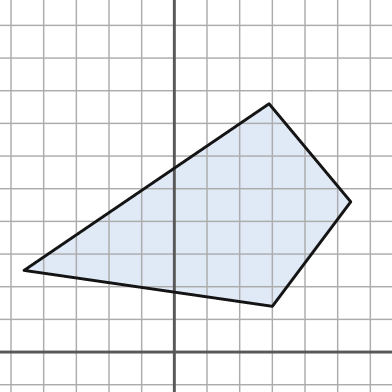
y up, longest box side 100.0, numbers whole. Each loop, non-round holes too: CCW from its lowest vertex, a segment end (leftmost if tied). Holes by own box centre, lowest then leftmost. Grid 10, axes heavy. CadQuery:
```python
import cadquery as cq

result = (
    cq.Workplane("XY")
    .moveTo(30.0, 14.0)
    .lineTo(54.0, 46.0)
    .lineTo(29.0, 76.0)
    .lineTo(-46.0, 25.0)
    .close()
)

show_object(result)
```